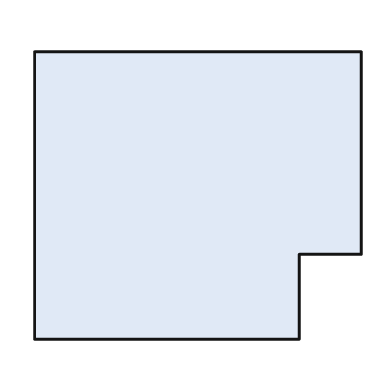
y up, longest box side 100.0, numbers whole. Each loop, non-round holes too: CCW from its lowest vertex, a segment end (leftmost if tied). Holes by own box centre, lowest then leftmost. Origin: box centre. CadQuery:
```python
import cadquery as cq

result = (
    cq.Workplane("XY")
    .moveTo(-50.0, -44.0)
    .lineTo(31.0, -44.0)
    .lineTo(31.0, -18.0)
    .lineTo(50.0, -18.0)
    .lineTo(50.0, 44.0)
    .lineTo(-50.0, 44.0)
    .close()
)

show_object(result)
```